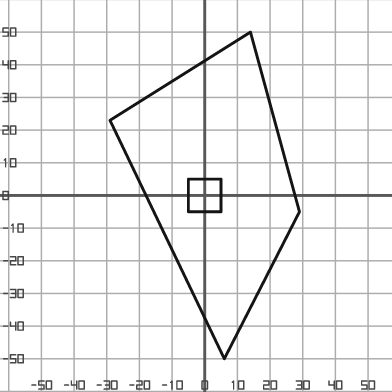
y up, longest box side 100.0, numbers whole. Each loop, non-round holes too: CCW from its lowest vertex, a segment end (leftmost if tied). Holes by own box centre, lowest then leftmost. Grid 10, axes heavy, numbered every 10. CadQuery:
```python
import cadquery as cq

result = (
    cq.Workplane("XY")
    .moveTo(6.0, -50.0)
    .lineTo(29.0, -5.0)
    .lineTo(14.0, 50.0)
    .lineTo(-29.0, 23.0)
    .close()
    .moveTo(-5.0, -5.0)
    .lineTo(5.0, -5.0)
    .lineTo(5.0, 5.0)
    .lineTo(-5.0, 5.0)
    .close()
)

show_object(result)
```